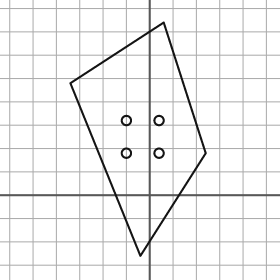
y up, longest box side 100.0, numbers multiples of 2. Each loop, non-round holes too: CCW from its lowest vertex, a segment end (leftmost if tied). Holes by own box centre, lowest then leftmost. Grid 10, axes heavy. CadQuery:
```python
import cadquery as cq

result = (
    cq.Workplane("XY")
    .moveTo(-4.0, -26.0)
    .lineTo(24.0, 18.0)
    .lineTo(6.0, 74.0)
    .lineTo(-34.0, 48.0)
    .close()
    .moveTo(-10.0, 18.0)
    .circle(2.0)
    .moveTo(4.0, 18.0)
    .circle(2.0)
    .moveTo(-10.0, 32.0)
    .circle(2.0)
    .moveTo(4.0, 32.0)
    .circle(2.0)
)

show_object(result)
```